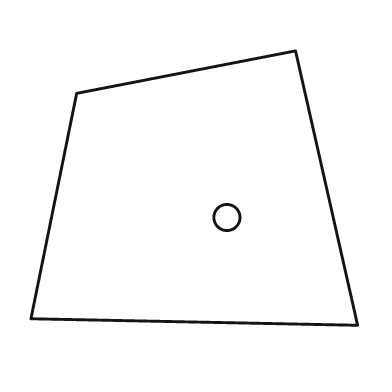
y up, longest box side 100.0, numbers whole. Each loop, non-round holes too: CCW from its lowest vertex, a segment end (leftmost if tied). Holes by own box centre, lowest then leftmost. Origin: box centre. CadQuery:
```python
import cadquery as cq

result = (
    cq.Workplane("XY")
    .moveTo(50.0, -42.0)
    .lineTo(31.0, 42.0)
    .lineTo(-36.0, 29.0)
    .lineTo(-50.0, -40.0)
    .close()
    .moveTo(10.0, -9.0)
    .circle(4.0)
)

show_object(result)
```